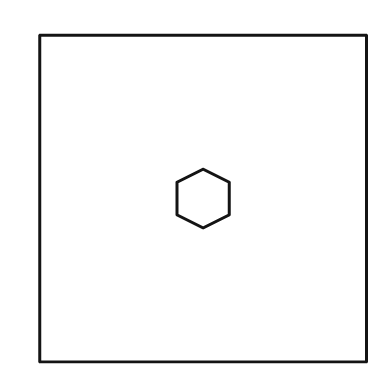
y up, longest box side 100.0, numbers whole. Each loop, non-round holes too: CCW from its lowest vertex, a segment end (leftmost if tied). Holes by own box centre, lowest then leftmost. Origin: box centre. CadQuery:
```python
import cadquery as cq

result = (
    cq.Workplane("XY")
    .moveTo(-50.0, -50.0)
    .lineTo(50.0, -50.0)
    .lineTo(50.0, 50.0)
    .lineTo(-50.0, 50.0)
    .close()
    .moveTo(0.0, -9.0)
    .lineTo(8.0, -5.0)
    .lineTo(8.0, 5.0)
    .lineTo(0.0, 9.0)
    .lineTo(-8.0, 5.0)
    .lineTo(-8.0, -5.0)
    .close()
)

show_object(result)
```